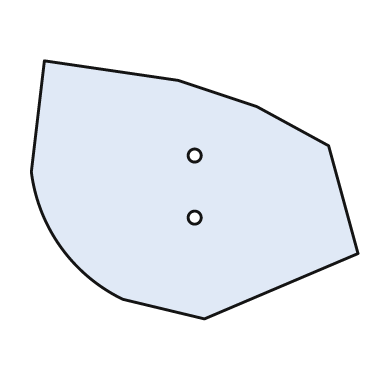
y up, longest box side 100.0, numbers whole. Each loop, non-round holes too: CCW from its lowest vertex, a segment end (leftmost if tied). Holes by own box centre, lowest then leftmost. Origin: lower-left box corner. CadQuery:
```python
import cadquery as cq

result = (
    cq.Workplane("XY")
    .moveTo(53.0, 0.0)
    .lineTo(100.0, 20.0)
    .lineTo(91.0, 53.0)
    .lineTo(69.0, 65.0)
    .lineTo(45.0, 73.0)
    .lineTo(4.0, 79.0)
    .lineTo(0.0, 45.0)
    .threePointArc((9.0, 22.0), (28.0, 6.0))
    .close()
    .moveTo(50.0, 31.0)
    .circle(2.0)
    .moveTo(50.0, 50.0)
    .circle(2.0)
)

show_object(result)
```